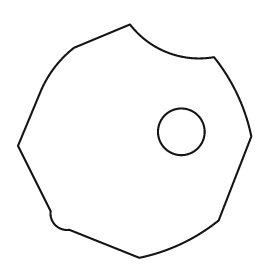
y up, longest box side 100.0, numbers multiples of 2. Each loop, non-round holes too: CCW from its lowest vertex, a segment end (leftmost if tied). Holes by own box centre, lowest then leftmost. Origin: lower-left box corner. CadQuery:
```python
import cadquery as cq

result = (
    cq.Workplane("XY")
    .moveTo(52.0, 0.0)
    .threePointArc((70.0, 6.0), (86.0, 16.0))
    .lineTo(100.0, 52.0)
    .threePointArc((94.0, 70.0), (84.0, 86.0))
    .threePointArc((64.0, 88.0), (48.0, 100.0))
    .lineTo(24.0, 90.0)
    .threePointArc((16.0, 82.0), (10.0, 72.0))
    .lineTo(0.0, 48.0)
    .lineTo(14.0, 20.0)
    .threePointArc((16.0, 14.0), (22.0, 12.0))
    .close()
    .moveTo(70.0, 54.0)
    .circle(10.0)
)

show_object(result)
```